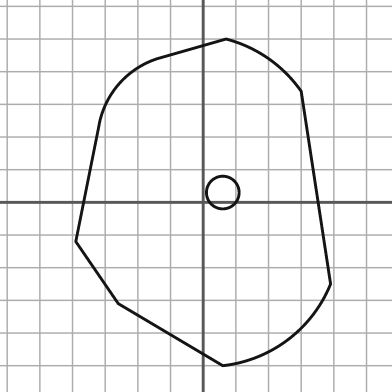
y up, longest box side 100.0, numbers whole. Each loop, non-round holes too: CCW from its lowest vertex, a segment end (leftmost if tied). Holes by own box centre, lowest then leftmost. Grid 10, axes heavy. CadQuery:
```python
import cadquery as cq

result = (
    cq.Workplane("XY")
    .moveTo(6.0, -50.0)
    .threePointArc((26.0, -42.0), (39.0, -25.0))
    .lineTo(30.0, 34.0)
    .threePointArc((20.0, 44.0), (7.0, 50.0))
    .lineTo(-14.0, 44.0)
    .threePointArc((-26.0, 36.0), (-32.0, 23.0))
    .lineTo(-39.0, -12.0)
    .lineTo(-26.0, -31.0)
    .close()
    .moveTo(6.0, 3.0)
    .circle(5.0)
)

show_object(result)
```